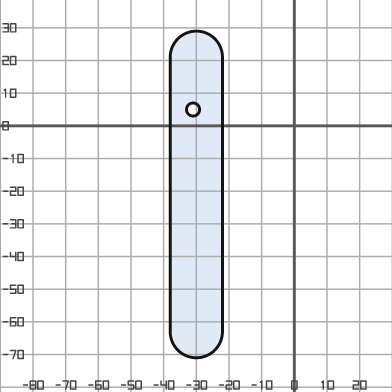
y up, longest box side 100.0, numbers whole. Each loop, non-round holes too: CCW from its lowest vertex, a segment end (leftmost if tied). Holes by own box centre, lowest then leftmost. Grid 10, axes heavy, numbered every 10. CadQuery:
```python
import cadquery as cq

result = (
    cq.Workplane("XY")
    .moveTo(-38.0, -63.0)
    .threePointArc((-30.0, -71.0), (-22.0, -63.0))
    .lineTo(-22.0, 21.0)
    .threePointArc((-30.0, 29.0), (-38.0, 21.0))
    .close()
    .moveTo(-31.0, 5.0)
    .circle(2.0)
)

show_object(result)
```